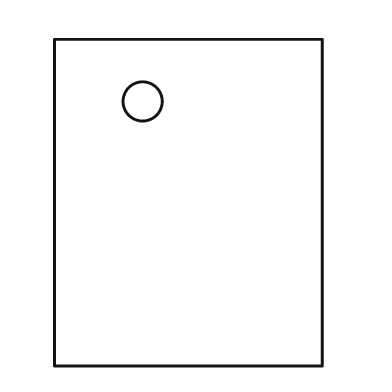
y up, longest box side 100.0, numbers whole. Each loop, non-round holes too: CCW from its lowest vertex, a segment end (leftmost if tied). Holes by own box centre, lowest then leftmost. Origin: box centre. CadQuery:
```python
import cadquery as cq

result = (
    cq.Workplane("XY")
    .moveTo(-41.0, -50.0)
    .lineTo(41.0, -50.0)
    .lineTo(41.0, 50.0)
    .lineTo(-41.0, 50.0)
    .close()
    .moveTo(-14.0, 31.0)
    .circle(6.0)
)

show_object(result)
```